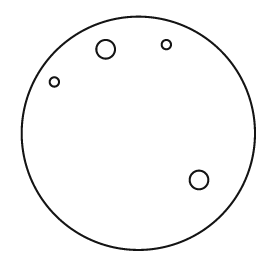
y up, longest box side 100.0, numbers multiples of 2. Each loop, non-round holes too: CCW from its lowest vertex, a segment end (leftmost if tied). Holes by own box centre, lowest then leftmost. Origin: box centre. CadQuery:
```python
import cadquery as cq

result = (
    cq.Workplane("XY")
    .moveTo(0.0, 0.0)
    .circle(50.0)
    .moveTo(26.0, -20.0)
    .circle(4.0)
    .moveTo(-36.0, 22.0)
    .circle(2.0)
    .moveTo(-14.0, 36.0)
    .circle(4.0)
    .moveTo(12.0, 38.0)
    .circle(2.0)
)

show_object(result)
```